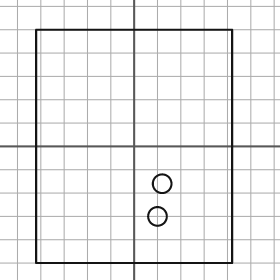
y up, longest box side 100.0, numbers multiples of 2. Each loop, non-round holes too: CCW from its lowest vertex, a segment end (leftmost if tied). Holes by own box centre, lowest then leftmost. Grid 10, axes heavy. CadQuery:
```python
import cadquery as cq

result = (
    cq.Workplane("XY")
    .moveTo(-42.0, -50.0)
    .lineTo(42.0, -50.0)
    .lineTo(42.0, 50.0)
    .lineTo(-42.0, 50.0)
    .close()
    .moveTo(10.0, -30.0)
    .circle(4.0)
    .moveTo(12.0, -16.0)
    .circle(4.0)
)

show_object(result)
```